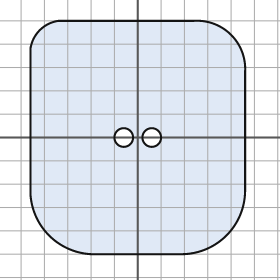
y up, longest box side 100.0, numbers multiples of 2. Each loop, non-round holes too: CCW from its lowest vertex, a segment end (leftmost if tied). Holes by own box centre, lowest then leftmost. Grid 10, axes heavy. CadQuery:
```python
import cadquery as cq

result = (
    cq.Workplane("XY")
    .moveTo(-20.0, -50.0)
    .lineTo(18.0, -50.0)
    .threePointArc((38.0, -42.0), (46.0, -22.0))
    .lineTo(46.0, 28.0)
    .threePointArc((40.0, 44.0), (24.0, 50.0))
    .lineTo(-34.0, 50.0)
    .threePointArc((-42.0, 46.0), (-46.0, 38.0))
    .lineTo(-46.0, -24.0)
    .threePointArc((-38.0, -42.0), (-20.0, -50.0))
    .close()
    .moveTo(-6.0, 0.0)
    .circle(4.0)
    .moveTo(6.0, 0.0)
    .circle(4.0)
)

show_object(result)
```